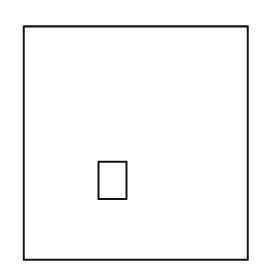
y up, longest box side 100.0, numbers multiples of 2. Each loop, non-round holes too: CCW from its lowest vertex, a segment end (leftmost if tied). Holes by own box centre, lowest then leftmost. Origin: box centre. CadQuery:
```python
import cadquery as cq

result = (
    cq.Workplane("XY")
    .moveTo(-48.0, -50.0)
    .lineTo(48.0, -50.0)
    .lineTo(48.0, 50.0)
    .lineTo(-48.0, 50.0)
    .close()
    .moveTo(-16.0, -24.0)
    .lineTo(-4.0, -24.0)
    .lineTo(-4.0, -8.0)
    .lineTo(-16.0, -8.0)
    .close()
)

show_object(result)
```